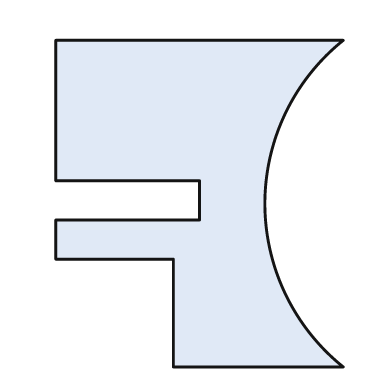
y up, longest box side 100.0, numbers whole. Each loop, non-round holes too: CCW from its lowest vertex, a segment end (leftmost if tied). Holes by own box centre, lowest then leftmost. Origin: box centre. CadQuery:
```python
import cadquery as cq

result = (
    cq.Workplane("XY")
    .moveTo(-8.0, -50.0)
    .lineTo(44.0, -50.0)
    .threePointArc((20.0, 0.0), (44.0, 50.0))
    .lineTo(-44.0, 50.0)
    .lineTo(-44.0, 7.0)
    .lineTo(0.0, 7.0)
    .lineTo(0.0, -5.0)
    .lineTo(-44.0, -5.0)
    .lineTo(-44.0, -17.0)
    .lineTo(-8.0, -17.0)
    .close()
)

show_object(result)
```